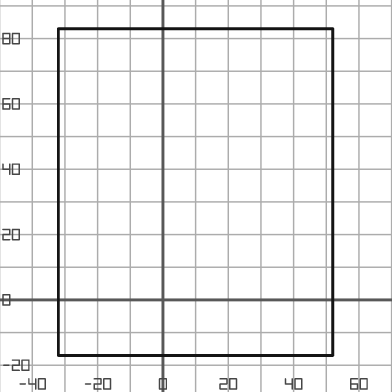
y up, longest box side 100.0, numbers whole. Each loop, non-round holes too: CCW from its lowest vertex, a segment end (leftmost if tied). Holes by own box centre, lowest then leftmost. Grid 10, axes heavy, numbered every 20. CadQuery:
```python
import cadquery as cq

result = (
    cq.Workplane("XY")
    .moveTo(-32.0, -17.0)
    .lineTo(52.0, -17.0)
    .lineTo(52.0, 83.0)
    .lineTo(-32.0, 83.0)
    .close()
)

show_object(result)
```